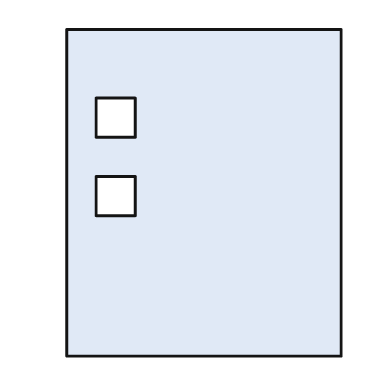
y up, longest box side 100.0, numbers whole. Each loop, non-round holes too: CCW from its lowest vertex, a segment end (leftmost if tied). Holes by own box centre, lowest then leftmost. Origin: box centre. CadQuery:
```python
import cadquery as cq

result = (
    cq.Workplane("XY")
    .moveTo(-42.0, -50.0)
    .lineTo(42.0, -50.0)
    .lineTo(42.0, 50.0)
    .lineTo(-42.0, 50.0)
    .close()
    .moveTo(-33.0, -7.0)
    .lineTo(-21.0, -7.0)
    .lineTo(-21.0, 5.0)
    .lineTo(-33.0, 5.0)
    .close()
    .moveTo(-33.0, 17.0)
    .lineTo(-21.0, 17.0)
    .lineTo(-21.0, 29.0)
    .lineTo(-33.0, 29.0)
    .close()
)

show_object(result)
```